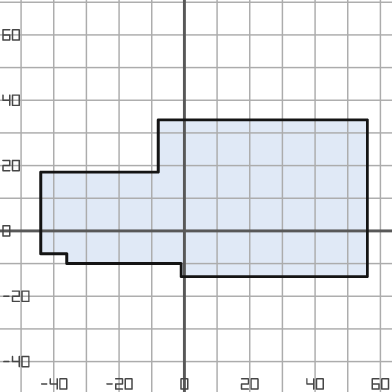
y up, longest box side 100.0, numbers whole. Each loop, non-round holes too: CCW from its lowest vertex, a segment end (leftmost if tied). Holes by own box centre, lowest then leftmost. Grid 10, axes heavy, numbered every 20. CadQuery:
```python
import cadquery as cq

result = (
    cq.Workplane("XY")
    .moveTo(-1.0, -14.0)
    .lineTo(56.0, -14.0)
    .lineTo(56.0, 34.0)
    .lineTo(-8.0, 34.0)
    .lineTo(-8.0, 18.0)
    .lineTo(-44.0, 18.0)
    .lineTo(-44.0, -7.0)
    .lineTo(-36.0, -7.0)
    .lineTo(-36.0, -10.0)
    .lineTo(-1.0, -10.0)
    .close()
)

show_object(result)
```